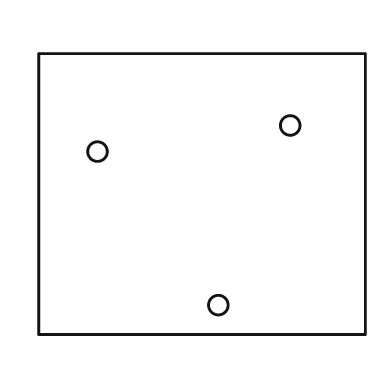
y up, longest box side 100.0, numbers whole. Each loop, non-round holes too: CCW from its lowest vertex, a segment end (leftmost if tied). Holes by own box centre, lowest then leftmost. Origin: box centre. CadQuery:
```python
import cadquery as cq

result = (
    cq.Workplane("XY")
    .moveTo(-50.0, -43.0)
    .lineTo(50.0, -43.0)
    .lineTo(50.0, 43.0)
    .lineTo(-50.0, 43.0)
    .close()
    .moveTo(5.0, -34.0)
    .circle(3.0)
    .moveTo(-32.0, 13.0)
    .circle(3.0)
    .moveTo(27.0, 21.0)
    .circle(3.0)
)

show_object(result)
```